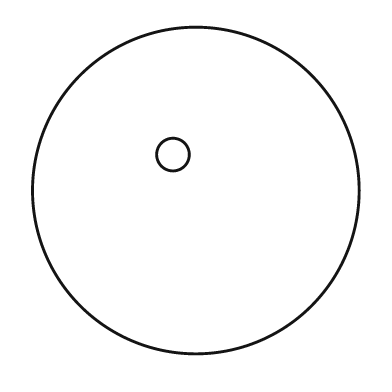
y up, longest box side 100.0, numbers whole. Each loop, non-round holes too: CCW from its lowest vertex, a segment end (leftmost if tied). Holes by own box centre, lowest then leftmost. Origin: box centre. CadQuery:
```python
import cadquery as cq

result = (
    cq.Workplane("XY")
    .moveTo(0.0, 0.0)
    .circle(50.0)
    .moveTo(-7.0, 11.0)
    .circle(5.0)
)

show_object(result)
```